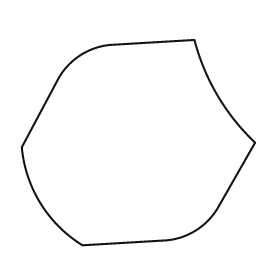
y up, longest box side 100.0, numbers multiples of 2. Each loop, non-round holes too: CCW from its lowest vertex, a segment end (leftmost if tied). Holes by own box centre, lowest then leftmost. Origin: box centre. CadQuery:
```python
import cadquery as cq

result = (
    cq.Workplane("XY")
    .moveTo(-24.0, -44.0)
    .lineTo(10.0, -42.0)
    .threePointArc((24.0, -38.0), (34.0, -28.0))
    .lineTo(50.0, 0.0)
    .threePointArc((34.0, 20.0), (24.0, 44.0))
    .lineTo(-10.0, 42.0)
    .threePointArc((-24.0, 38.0), (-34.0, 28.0))
    .lineTo(-50.0, -2.0)
    .threePointArc((-42.0, -26.0), (-24.0, -44.0))
    .close()
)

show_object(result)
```